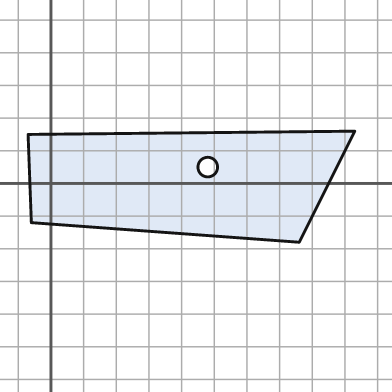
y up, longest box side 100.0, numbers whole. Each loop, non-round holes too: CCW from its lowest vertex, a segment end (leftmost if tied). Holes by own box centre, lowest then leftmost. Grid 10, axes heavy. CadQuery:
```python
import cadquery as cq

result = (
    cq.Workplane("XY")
    .moveTo(76.0, -18.0)
    .lineTo(93.0, 16.0)
    .lineTo(-7.0, 15.0)
    .lineTo(-6.0, -12.0)
    .close()
    .moveTo(48.0, 5.0)
    .circle(3.0)
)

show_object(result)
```